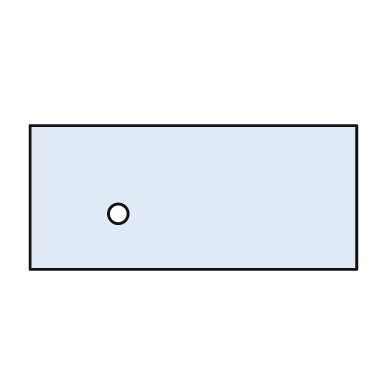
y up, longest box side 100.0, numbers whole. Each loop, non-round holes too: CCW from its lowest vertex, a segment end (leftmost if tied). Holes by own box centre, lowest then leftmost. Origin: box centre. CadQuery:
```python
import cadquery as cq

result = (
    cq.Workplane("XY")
    .moveTo(-50.0, -22.0)
    .lineTo(50.0, -22.0)
    .lineTo(50.0, 22.0)
    .lineTo(-50.0, 22.0)
    .close()
    .moveTo(-23.0, -5.0)
    .circle(3.0)
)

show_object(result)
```